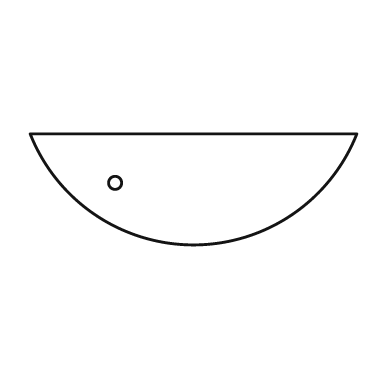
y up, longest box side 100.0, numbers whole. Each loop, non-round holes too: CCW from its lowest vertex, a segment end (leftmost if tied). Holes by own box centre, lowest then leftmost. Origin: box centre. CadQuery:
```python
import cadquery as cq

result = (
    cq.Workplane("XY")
    .moveTo(-50.0, 17.0)
    .threePointArc((0.0, -17.0), (50.0, 17.0))
    .close()
    .moveTo(-24.0, 2.0)
    .circle(2.0)
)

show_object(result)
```